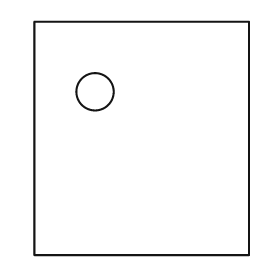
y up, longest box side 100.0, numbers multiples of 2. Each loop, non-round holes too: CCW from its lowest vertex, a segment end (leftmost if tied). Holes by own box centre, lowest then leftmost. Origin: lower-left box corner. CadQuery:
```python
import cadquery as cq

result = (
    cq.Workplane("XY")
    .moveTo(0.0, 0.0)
    .lineTo(92.0, 0.0)
    .lineTo(92.0, 100.0)
    .lineTo(0.0, 100.0)
    .close()
    .moveTo(26.0, 70.0)
    .circle(8.0)
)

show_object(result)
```